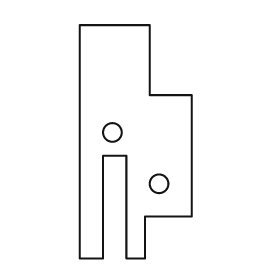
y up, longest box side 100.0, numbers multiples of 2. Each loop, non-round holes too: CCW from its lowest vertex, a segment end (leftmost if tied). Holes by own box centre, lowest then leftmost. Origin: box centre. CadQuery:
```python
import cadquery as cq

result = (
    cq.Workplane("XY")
    .moveTo(-24.0, -50.0)
    .lineTo(-14.0, -50.0)
    .lineTo(-14.0, -6.0)
    .lineTo(-4.0, -6.0)
    .lineTo(-4.0, -50.0)
    .lineTo(4.0, -50.0)
    .lineTo(4.0, -32.0)
    .lineTo(24.0, -32.0)
    .lineTo(24.0, 20.0)
    .lineTo(6.0, 20.0)
    .lineTo(6.0, 50.0)
    .lineTo(-24.0, 50.0)
    .close()
    .moveTo(10.0, -18.0)
    .circle(4.0)
    .moveTo(-10.0, 4.0)
    .circle(4.0)
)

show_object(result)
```